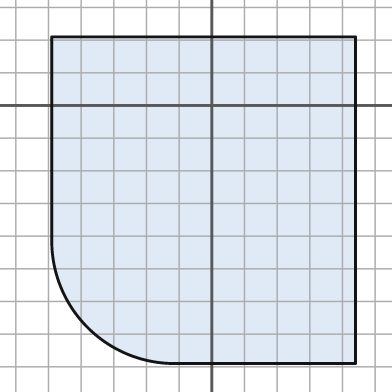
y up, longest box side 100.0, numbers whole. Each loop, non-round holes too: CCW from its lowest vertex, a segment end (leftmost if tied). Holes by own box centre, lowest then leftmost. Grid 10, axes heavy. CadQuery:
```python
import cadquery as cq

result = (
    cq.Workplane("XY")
    .moveTo(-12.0, -79.0)
    .lineTo(44.0, -79.0)
    .lineTo(44.0, 21.0)
    .lineTo(-49.0, 21.0)
    .lineTo(-49.0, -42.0)
    .threePointArc((-38.0, -68.0), (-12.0, -79.0))
    .close()
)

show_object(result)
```